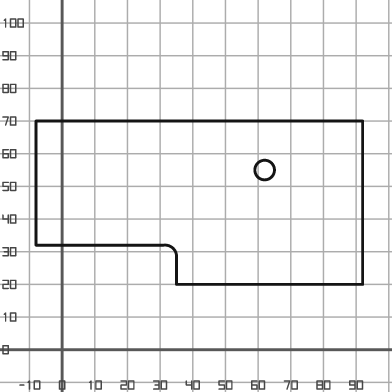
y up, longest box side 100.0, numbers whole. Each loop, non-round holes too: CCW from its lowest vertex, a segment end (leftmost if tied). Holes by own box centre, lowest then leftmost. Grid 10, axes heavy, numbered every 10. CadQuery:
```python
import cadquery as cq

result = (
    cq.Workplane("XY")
    .moveTo(35.0, 20.0)
    .lineTo(92.0, 20.0)
    .lineTo(92.0, 70.0)
    .lineTo(-8.0, 70.0)
    .lineTo(-8.0, 32.0)
    .lineTo(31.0, 32.0)
    .threePointArc((34.0, 31.0), (35.0, 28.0))
    .close()
    .moveTo(62.0, 55.0)
    .circle(3.0)
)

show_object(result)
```